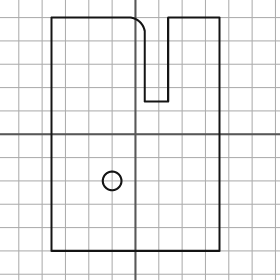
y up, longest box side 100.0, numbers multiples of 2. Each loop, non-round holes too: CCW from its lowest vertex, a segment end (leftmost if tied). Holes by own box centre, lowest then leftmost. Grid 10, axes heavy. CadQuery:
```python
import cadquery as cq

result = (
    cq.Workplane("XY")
    .moveTo(-36.0, -50.0)
    .lineTo(36.0, -50.0)
    .lineTo(36.0, 50.0)
    .lineTo(14.0, 50.0)
    .lineTo(14.0, 14.0)
    .lineTo(4.0, 14.0)
    .lineTo(4.0, 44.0)
    .threePointArc((2.0, 48.0), (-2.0, 50.0))
    .lineTo(-36.0, 50.0)
    .close()
    .moveTo(-10.0, -20.0)
    .circle(4.0)
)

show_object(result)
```